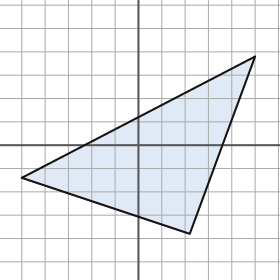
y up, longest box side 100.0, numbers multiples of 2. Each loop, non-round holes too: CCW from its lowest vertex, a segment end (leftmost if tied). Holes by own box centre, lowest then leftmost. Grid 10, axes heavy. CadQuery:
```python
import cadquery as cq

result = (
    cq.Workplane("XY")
    .moveTo(22.0, -38.0)
    .lineTo(50.0, 38.0)
    .lineTo(-50.0, -14.0)
    .close()
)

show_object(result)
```